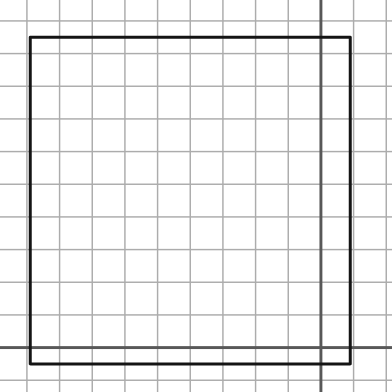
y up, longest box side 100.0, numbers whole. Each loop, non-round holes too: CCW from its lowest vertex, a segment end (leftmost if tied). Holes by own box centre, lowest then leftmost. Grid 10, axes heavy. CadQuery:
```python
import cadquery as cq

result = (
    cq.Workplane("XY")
    .moveTo(-89.0, -5.0)
    .lineTo(9.0, -5.0)
    .lineTo(9.0, 95.0)
    .lineTo(-89.0, 95.0)
    .close()
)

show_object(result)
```